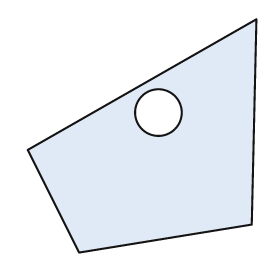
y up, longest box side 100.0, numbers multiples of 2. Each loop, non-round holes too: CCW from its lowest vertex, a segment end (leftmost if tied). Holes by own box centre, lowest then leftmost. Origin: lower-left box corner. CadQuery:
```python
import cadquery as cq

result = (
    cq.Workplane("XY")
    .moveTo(22.0, 0.0)
    .lineTo(96.0, 12.0)
    .lineTo(98.0, 100.0)
    .lineTo(0.0, 44.0)
    .close()
    .moveTo(56.0, 60.0)
    .circle(10.0)
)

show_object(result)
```